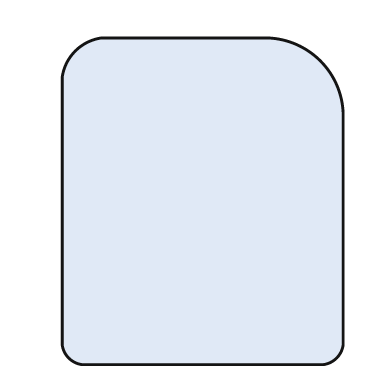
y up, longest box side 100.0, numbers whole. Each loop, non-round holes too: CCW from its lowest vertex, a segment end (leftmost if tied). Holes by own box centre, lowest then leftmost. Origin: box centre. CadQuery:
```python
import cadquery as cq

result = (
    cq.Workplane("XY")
    .moveTo(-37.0, -50.0)
    .lineTo(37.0, -50.0)
    .threePointArc((41.0, -48.0), (43.0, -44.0))
    .lineTo(43.0, 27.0)
    .threePointArc((36.0, 43.0), (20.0, 50.0))
    .lineTo(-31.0, 50.0)
    .threePointArc((-39.0, 46.0), (-43.0, 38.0))
    .lineTo(-43.0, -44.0)
    .threePointArc((-41.0, -48.0), (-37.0, -50.0))
    .close()
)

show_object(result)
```